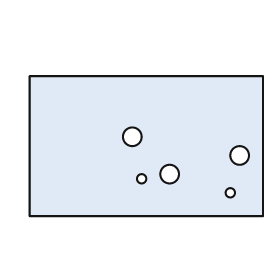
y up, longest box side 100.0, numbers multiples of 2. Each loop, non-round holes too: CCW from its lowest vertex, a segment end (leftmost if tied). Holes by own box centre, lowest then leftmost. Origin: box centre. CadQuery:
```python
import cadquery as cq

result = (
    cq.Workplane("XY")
    .moveTo(-50.0, -30.0)
    .lineTo(50.0, -30.0)
    .lineTo(50.0, 30.0)
    .lineTo(-50.0, 30.0)
    .close()
    .moveTo(36.0, -20.0)
    .circle(2.0)
    .moveTo(-2.0, -14.0)
    .circle(2.0)
    .moveTo(10.0, -12.0)
    .circle(4.0)
    .moveTo(40.0, -4.0)
    .circle(4.0)
    .moveTo(-6.0, 4.0)
    .circle(4.0)
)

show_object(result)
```